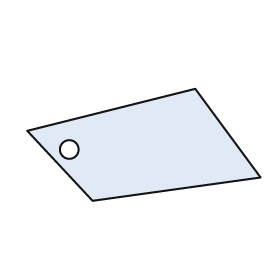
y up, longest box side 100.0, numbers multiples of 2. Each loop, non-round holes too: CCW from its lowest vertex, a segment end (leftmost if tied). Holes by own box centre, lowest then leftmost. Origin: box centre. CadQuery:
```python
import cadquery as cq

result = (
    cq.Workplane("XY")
    .moveTo(-22.0, -24.0)
    .lineTo(50.0, -14.0)
    .lineTo(22.0, 24.0)
    .lineTo(-50.0, 6.0)
    .close()
    .moveTo(-32.0, -2.0)
    .circle(4.0)
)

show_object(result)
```